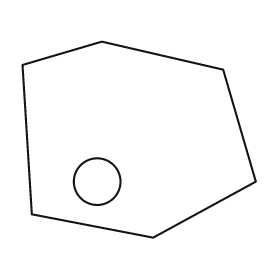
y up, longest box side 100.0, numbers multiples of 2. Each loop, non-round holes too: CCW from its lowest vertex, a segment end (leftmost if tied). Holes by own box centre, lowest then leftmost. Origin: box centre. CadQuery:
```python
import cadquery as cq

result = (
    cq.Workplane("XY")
    .moveTo(6.0, -42.0)
    .lineTo(50.0, -18.0)
    .lineTo(36.0, 30.0)
    .lineTo(-16.0, 42.0)
    .lineTo(-50.0, 32.0)
    .lineTo(-46.0, -32.0)
    .close()
    .moveTo(-18.0, -18.0)
    .circle(10.0)
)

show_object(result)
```